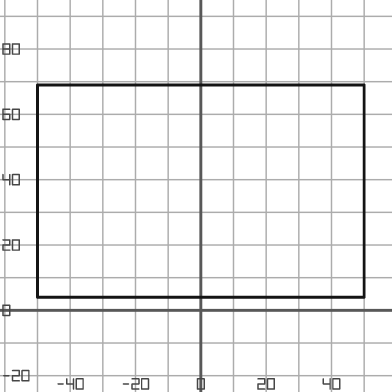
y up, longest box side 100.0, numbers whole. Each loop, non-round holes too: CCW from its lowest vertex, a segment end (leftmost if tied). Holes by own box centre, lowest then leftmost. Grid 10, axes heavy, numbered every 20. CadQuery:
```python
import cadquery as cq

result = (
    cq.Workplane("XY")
    .moveTo(-50.0, 4.0)
    .lineTo(50.0, 4.0)
    .lineTo(50.0, 69.0)
    .lineTo(-50.0, 69.0)
    .close()
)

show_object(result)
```